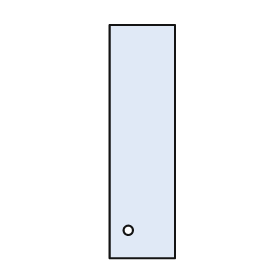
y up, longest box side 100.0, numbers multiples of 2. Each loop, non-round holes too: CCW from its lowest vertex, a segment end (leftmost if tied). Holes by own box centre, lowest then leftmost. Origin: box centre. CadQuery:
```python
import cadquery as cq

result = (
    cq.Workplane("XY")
    .moveTo(-14.0, -50.0)
    .lineTo(14.0, -50.0)
    .lineTo(14.0, 50.0)
    .lineTo(-14.0, 50.0)
    .close()
    .moveTo(-6.0, -38.0)
    .circle(2.0)
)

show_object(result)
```